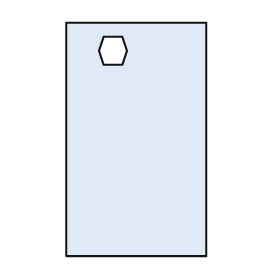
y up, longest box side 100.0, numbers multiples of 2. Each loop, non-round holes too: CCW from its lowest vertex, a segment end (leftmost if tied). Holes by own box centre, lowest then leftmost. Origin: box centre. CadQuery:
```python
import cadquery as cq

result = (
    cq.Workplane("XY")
    .moveTo(-30.0, -50.0)
    .lineTo(30.0, -50.0)
    .lineTo(30.0, 50.0)
    .lineTo(-30.0, 50.0)
    .close()
    .moveTo(-14.0, 32.0)
    .lineTo(-6.0, 32.0)
    .lineTo(-4.0, 38.0)
    .lineTo(-6.0, 44.0)
    .lineTo(-14.0, 44.0)
    .lineTo(-16.0, 38.0)
    .close()
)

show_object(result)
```